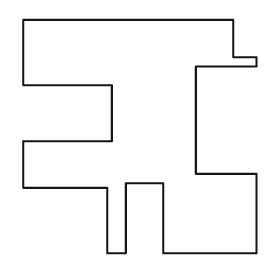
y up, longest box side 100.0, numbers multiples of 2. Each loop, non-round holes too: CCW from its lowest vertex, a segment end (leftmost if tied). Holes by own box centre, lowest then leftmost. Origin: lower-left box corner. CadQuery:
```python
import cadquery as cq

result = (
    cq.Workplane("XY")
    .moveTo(36.0, 0.0)
    .lineTo(44.0, 0.0)
    .lineTo(44.0, 30.0)
    .lineTo(60.0, 30.0)
    .lineTo(60.0, 0.0)
    .lineTo(100.0, 0.0)
    .lineTo(100.0, 34.0)
    .lineTo(74.0, 34.0)
    .lineTo(74.0, 80.0)
    .lineTo(100.0, 80.0)
    .lineTo(100.0, 84.0)
    .lineTo(90.0, 84.0)
    .lineTo(90.0, 100.0)
    .lineTo(0.0, 100.0)
    .lineTo(0.0, 72.0)
    .lineTo(38.0, 72.0)
    .lineTo(38.0, 48.0)
    .lineTo(0.0, 48.0)
    .lineTo(0.0, 28.0)
    .lineTo(36.0, 28.0)
    .close()
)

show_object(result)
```